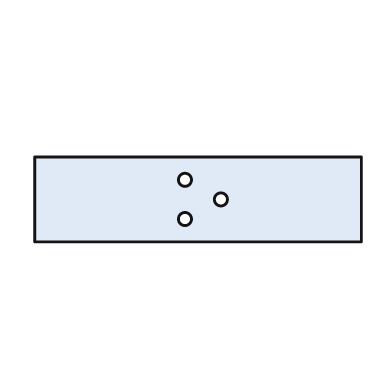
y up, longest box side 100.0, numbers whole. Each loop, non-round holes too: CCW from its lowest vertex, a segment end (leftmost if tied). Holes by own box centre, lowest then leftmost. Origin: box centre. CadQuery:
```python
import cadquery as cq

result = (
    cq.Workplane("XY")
    .moveTo(-50.0, -13.0)
    .lineTo(50.0, -13.0)
    .lineTo(50.0, 13.0)
    .lineTo(-50.0, 13.0)
    .close()
    .moveTo(-4.0, -6.0)
    .circle(2.0)
    .moveTo(7.0, 0.0)
    .circle(2.0)
    .moveTo(-4.0, 6.0)
    .circle(2.0)
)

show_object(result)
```